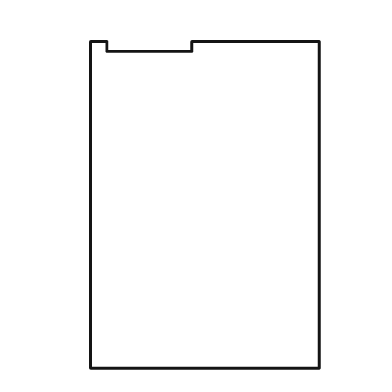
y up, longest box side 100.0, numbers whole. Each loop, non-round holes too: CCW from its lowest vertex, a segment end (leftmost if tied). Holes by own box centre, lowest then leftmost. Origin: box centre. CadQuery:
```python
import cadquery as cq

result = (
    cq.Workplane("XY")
    .moveTo(-35.0, -50.0)
    .lineTo(35.0, -50.0)
    .lineTo(35.0, 50.0)
    .lineTo(-4.0, 50.0)
    .lineTo(-4.0, 47.0)
    .lineTo(-30.0, 47.0)
    .lineTo(-30.0, 50.0)
    .lineTo(-35.0, 50.0)
    .close()
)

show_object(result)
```